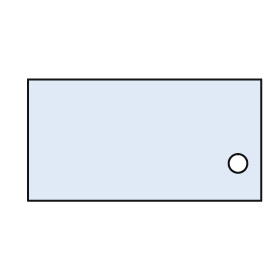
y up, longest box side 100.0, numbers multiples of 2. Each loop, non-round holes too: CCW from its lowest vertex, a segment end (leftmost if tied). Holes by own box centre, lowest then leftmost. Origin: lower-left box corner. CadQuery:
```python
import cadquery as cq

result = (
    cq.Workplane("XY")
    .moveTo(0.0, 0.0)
    .lineTo(100.0, 0.0)
    .lineTo(100.0, 52.0)
    .lineTo(0.0, 52.0)
    .close()
    .moveTo(90.0, 16.0)
    .circle(4.0)
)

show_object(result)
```